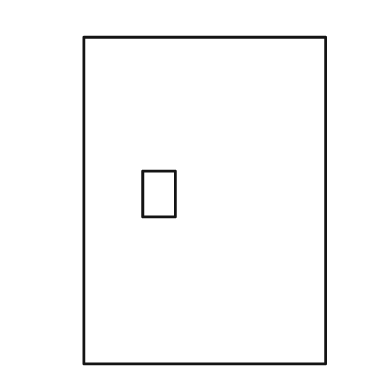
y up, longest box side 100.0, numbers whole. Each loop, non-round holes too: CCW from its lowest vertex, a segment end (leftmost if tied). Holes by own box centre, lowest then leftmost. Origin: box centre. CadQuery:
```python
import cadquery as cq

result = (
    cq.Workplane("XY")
    .moveTo(-37.0, -50.0)
    .lineTo(37.0, -50.0)
    .lineTo(37.0, 50.0)
    .lineTo(-37.0, 50.0)
    .close()
    .moveTo(-19.0, -5.0)
    .lineTo(-9.0, -5.0)
    .lineTo(-9.0, 9.0)
    .lineTo(-19.0, 9.0)
    .close()
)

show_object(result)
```